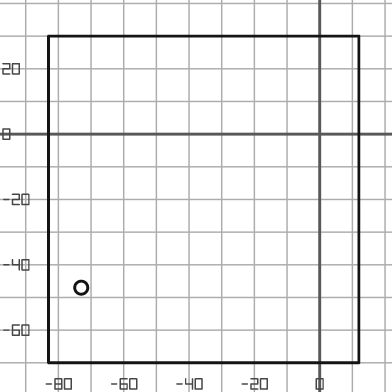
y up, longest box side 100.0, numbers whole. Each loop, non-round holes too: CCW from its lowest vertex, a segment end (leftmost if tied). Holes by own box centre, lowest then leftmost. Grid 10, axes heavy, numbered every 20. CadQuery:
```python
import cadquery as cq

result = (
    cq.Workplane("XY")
    .moveTo(-83.0, -70.0)
    .lineTo(12.0, -70.0)
    .lineTo(12.0, 30.0)
    .lineTo(-83.0, 30.0)
    .close()
    .moveTo(-73.0, -47.0)
    .circle(2.0)
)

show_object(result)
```